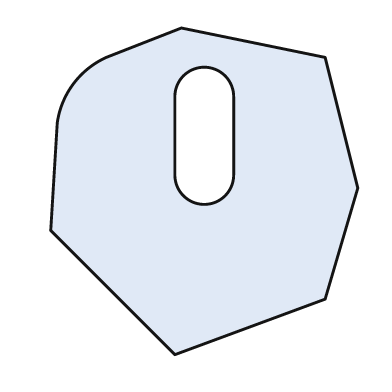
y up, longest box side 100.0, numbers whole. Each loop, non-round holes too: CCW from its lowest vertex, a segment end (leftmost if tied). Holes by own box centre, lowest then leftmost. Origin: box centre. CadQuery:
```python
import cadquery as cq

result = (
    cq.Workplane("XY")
    .moveTo(-9.0, -50.0)
    .lineTo(37.0, -33.0)
    .lineTo(47.0, 1.0)
    .lineTo(37.0, 41.0)
    .lineTo(-7.0, 50.0)
    .lineTo(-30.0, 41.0)
    .threePointArc((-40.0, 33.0), (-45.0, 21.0))
    .lineTo(-47.0, -12.0)
    .close()
    .moveTo(-9.0, 5.0)
    .threePointArc((0.0, -4.0), (9.0, 5.0))
    .lineTo(9.0, 29.0)
    .threePointArc((0.0, 38.0), (-9.0, 29.0))
    .close()
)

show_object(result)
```